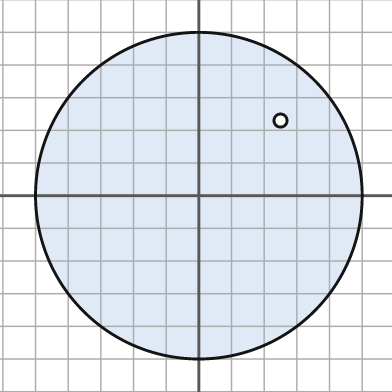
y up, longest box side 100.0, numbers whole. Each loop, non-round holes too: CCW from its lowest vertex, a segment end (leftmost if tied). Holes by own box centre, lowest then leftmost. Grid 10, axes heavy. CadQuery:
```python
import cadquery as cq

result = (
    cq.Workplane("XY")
    .moveTo(0.0, 0.0)
    .circle(50.0)
    .moveTo(25.0, 23.0)
    .circle(2.0)
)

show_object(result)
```